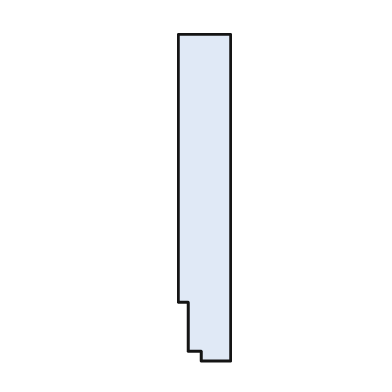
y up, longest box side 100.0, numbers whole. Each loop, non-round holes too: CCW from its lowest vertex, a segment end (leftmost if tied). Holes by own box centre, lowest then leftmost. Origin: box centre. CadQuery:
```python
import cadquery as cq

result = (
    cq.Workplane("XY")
    .moveTo(-1.0, -50.0)
    .lineTo(8.0, -50.0)
    .lineTo(8.0, 50.0)
    .lineTo(-8.0, 50.0)
    .lineTo(-8.0, -32.0)
    .lineTo(-5.0, -32.0)
    .lineTo(-5.0, -47.0)
    .lineTo(-1.0, -47.0)
    .close()
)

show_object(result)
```